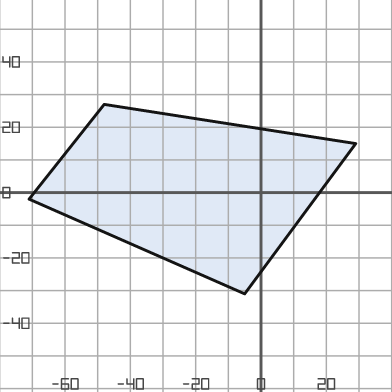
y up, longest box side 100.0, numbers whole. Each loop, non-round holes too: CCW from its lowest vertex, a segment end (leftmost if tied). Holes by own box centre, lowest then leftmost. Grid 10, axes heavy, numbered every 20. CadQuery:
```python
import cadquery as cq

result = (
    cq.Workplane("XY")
    .moveTo(-5.0, -31.0)
    .lineTo(29.0, 15.0)
    .lineTo(-48.0, 27.0)
    .lineTo(-71.0, -2.0)
    .close()
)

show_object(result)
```